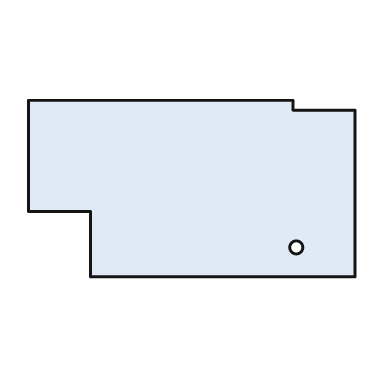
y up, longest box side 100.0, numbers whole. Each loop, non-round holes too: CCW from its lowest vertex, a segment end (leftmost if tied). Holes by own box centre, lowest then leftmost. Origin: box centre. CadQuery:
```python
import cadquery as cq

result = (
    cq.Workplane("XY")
    .moveTo(-31.0, -27.0)
    .lineTo(50.0, -27.0)
    .lineTo(50.0, 24.0)
    .lineTo(31.0, 24.0)
    .lineTo(31.0, 27.0)
    .lineTo(-50.0, 27.0)
    .lineTo(-50.0, -7.0)
    .lineTo(-31.0, -7.0)
    .close()
    .moveTo(32.0, -18.0)
    .circle(2.0)
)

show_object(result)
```